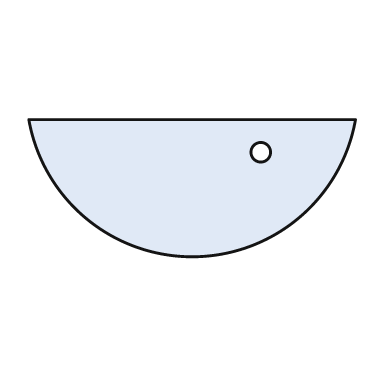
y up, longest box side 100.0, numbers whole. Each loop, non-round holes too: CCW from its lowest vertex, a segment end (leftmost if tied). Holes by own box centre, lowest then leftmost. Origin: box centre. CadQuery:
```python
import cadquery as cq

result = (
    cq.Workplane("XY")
    .moveTo(-50.0, 21.0)
    .threePointArc((0.0, -21.0), (50.0, 21.0))
    .close()
    .moveTo(21.0, 11.0)
    .circle(3.0)
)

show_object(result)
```